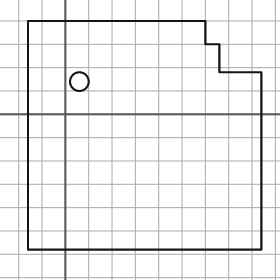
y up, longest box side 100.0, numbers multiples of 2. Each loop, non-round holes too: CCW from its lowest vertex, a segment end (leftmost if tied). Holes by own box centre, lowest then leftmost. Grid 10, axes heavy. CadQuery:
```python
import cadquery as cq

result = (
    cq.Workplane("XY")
    .moveTo(-16.0, -58.0)
    .lineTo(84.0, -58.0)
    .lineTo(84.0, 18.0)
    .lineTo(66.0, 18.0)
    .lineTo(66.0, 30.0)
    .lineTo(60.0, 30.0)
    .lineTo(60.0, 40.0)
    .lineTo(-16.0, 40.0)
    .close()
    .moveTo(6.0, 14.0)
    .circle(4.0)
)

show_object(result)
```